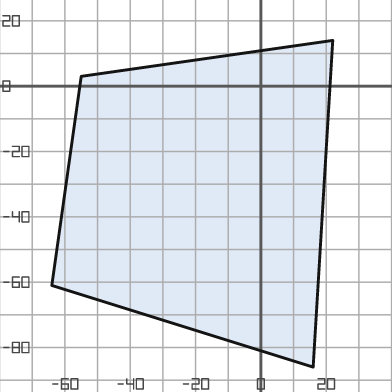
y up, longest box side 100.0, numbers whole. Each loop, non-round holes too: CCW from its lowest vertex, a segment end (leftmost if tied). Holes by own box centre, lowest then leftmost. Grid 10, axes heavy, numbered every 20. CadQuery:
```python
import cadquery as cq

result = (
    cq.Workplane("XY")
    .moveTo(16.0, -86.0)
    .lineTo(22.0, 14.0)
    .lineTo(-55.0, 3.0)
    .lineTo(-64.0, -61.0)
    .close()
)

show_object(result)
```